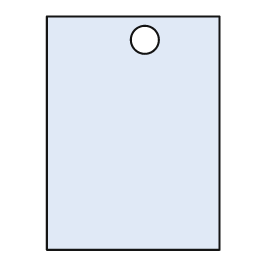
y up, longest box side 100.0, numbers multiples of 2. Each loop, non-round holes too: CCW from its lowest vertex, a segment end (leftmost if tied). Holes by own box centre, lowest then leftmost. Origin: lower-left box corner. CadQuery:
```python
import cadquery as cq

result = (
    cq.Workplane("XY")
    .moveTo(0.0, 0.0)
    .lineTo(74.0, 0.0)
    .lineTo(74.0, 100.0)
    .lineTo(0.0, 100.0)
    .close()
    .moveTo(42.0, 90.0)
    .circle(6.0)
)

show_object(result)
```